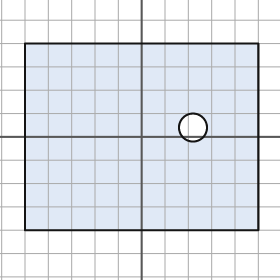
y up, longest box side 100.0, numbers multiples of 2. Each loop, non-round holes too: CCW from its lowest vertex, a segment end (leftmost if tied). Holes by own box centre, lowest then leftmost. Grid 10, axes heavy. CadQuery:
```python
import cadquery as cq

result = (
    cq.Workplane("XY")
    .moveTo(-50.0, -40.0)
    .lineTo(50.0, -40.0)
    .lineTo(50.0, 40.0)
    .lineTo(-50.0, 40.0)
    .close()
    .moveTo(22.0, 4.0)
    .circle(6.0)
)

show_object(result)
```